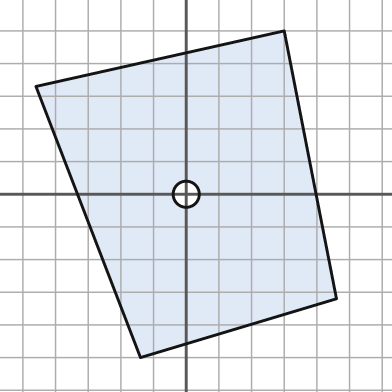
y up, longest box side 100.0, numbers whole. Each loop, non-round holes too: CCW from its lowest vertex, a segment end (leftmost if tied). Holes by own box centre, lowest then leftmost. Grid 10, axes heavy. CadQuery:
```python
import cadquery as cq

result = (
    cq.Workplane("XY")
    .moveTo(-14.0, -50.0)
    .lineTo(46.0, -32.0)
    .lineTo(30.0, 50.0)
    .lineTo(-46.0, 33.0)
    .close()
    .moveTo(0.0, 0.0)
    .circle(4.0)
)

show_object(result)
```